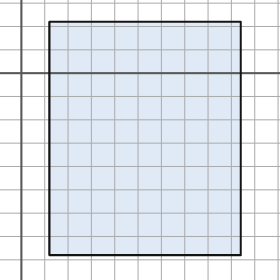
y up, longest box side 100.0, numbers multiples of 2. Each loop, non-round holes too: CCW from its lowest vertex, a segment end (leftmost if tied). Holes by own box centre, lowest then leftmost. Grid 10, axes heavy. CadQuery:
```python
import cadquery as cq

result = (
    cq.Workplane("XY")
    .moveTo(12.0, -78.0)
    .lineTo(94.0, -78.0)
    .lineTo(94.0, 22.0)
    .lineTo(12.0, 22.0)
    .close()
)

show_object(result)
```